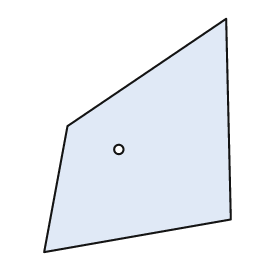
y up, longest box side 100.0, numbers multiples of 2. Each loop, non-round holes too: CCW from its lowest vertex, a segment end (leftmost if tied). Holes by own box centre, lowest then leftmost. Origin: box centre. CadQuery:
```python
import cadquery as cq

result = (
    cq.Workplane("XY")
    .moveTo(-40.0, -50.0)
    .lineTo(40.0, -36.0)
    .lineTo(38.0, 50.0)
    .lineTo(-30.0, 4.0)
    .close()
    .moveTo(-8.0, -6.0)
    .circle(2.0)
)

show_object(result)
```